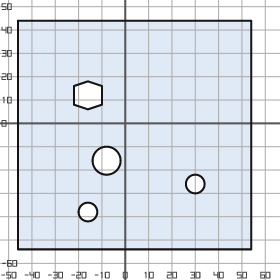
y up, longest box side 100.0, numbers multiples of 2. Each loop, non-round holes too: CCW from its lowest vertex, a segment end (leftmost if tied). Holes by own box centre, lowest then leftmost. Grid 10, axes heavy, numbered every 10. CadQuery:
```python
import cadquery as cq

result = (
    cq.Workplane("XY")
    .moveTo(-46.0, -54.0)
    .lineTo(54.0, -54.0)
    .lineTo(54.0, 44.0)
    .lineTo(-46.0, 44.0)
    .close()
    .moveTo(-16.0, -38.0)
    .circle(4.0)
    .moveTo(30.0, -26.0)
    .circle(4.0)
    .moveTo(-8.0, -16.0)
    .circle(6.0)
    .moveTo(-16.0, 6.0)
    .lineTo(-10.0, 8.0)
    .lineTo(-10.0, 16.0)
    .lineTo(-16.0, 18.0)
    .lineTo(-22.0, 16.0)
    .lineTo(-22.0, 8.0)
    .close()
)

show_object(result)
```